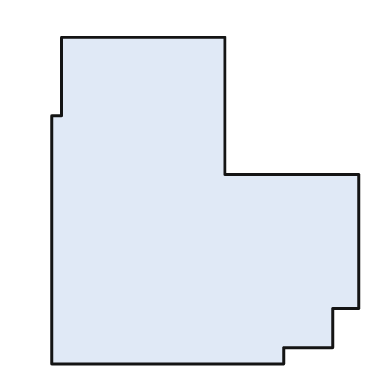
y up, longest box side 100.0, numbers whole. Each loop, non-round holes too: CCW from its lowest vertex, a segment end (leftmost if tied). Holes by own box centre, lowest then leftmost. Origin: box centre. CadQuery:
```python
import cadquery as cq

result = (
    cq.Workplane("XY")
    .moveTo(-47.0, -50.0)
    .lineTo(24.0, -50.0)
    .lineTo(24.0, -45.0)
    .lineTo(39.0, -45.0)
    .lineTo(39.0, -33.0)
    .lineTo(47.0, -33.0)
    .lineTo(47.0, 8.0)
    .lineTo(6.0, 8.0)
    .lineTo(6.0, 50.0)
    .lineTo(-44.0, 50.0)
    .lineTo(-44.0, 26.0)
    .lineTo(-47.0, 26.0)
    .close()
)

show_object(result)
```